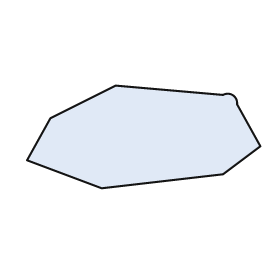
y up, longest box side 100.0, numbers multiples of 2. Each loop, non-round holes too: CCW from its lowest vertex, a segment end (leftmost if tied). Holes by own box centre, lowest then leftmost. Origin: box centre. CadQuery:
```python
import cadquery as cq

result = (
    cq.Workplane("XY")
    .moveTo(-18.0, -22.0)
    .lineTo(34.0, -16.0)
    .lineTo(50.0, -4.0)
    .lineTo(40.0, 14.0)
    .threePointArc((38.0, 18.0), (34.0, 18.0))
    .lineTo(-12.0, 22.0)
    .lineTo(-40.0, 8.0)
    .lineTo(-50.0, -10.0)
    .close()
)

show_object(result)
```